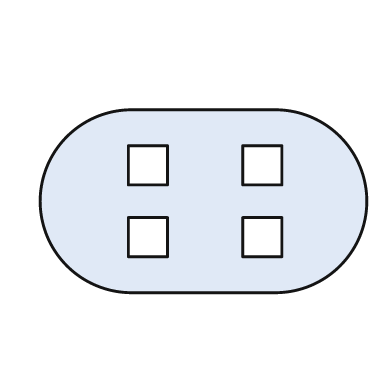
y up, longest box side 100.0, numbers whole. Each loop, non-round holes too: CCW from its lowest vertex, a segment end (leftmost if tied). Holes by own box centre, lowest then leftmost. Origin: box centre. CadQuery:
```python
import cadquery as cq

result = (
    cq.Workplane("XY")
    .moveTo(-22.0, -28.0)
    .lineTo(22.0, -28.0)
    .threePointArc((50.0, 0.0), (22.0, 28.0))
    .lineTo(-22.0, 28.0)
    .threePointArc((-50.0, 0.0), (-22.0, -28.0))
    .close()
    .moveTo(-23.0, -17.0)
    .lineTo(-11.0, -17.0)
    .lineTo(-11.0, -5.0)
    .lineTo(-23.0, -5.0)
    .close()
    .moveTo(12.0, -17.0)
    .lineTo(24.0, -17.0)
    .lineTo(24.0, -5.0)
    .lineTo(12.0, -5.0)
    .close()
    .moveTo(-23.0, 5.0)
    .lineTo(-11.0, 5.0)
    .lineTo(-11.0, 17.0)
    .lineTo(-23.0, 17.0)
    .close()
    .moveTo(12.0, 5.0)
    .lineTo(24.0, 5.0)
    .lineTo(24.0, 17.0)
    .lineTo(12.0, 17.0)
    .close()
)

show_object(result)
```